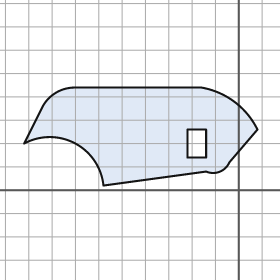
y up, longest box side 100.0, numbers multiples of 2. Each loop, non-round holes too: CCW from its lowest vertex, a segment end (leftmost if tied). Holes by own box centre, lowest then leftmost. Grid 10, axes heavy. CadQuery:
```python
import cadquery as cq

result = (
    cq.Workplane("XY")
    .moveTo(-58.0, 2.0)
    .lineTo(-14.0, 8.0)
    .threePointArc((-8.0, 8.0), (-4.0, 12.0))
    .lineTo(8.0, 26.0)
    .threePointArc((-2.0, 38.0), (-16.0, 44.0))
    .lineTo(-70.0, 44.0)
    .threePointArc((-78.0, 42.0), (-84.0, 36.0))
    .lineTo(-92.0, 20.0)
    .threePointArc((-70.0, 20.0), (-58.0, 2.0))
    .close()
    .moveTo(-22.0, 14.0)
    .lineTo(-14.0, 14.0)
    .lineTo(-14.0, 26.0)
    .lineTo(-22.0, 26.0)
    .close()
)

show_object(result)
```